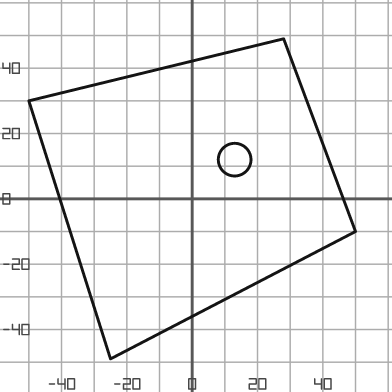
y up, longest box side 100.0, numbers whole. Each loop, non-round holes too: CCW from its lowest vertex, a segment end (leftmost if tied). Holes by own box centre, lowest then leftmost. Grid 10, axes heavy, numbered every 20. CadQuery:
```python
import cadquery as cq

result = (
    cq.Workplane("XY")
    .moveTo(-25.0, -49.0)
    .lineTo(50.0, -10.0)
    .lineTo(28.0, 49.0)
    .lineTo(-50.0, 30.0)
    .close()
    .moveTo(13.0, 12.0)
    .circle(5.0)
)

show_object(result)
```